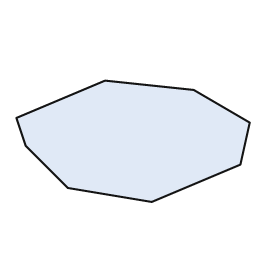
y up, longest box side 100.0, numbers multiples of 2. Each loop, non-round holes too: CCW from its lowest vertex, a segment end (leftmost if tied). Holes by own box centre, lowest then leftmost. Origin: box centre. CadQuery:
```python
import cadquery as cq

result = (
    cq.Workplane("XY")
    .moveTo(8.0, -26.0)
    .lineTo(46.0, -10.0)
    .lineTo(50.0, 8.0)
    .lineTo(26.0, 22.0)
    .lineTo(-12.0, 26.0)
    .lineTo(-50.0, 10.0)
    .lineTo(-46.0, -2.0)
    .lineTo(-28.0, -20.0)
    .close()
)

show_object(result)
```